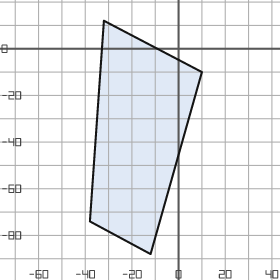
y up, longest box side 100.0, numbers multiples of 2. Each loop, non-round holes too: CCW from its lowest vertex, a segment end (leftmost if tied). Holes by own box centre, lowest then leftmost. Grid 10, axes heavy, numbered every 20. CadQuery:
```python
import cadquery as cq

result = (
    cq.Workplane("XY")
    .moveTo(-12.0, -88.0)
    .lineTo(10.0, -10.0)
    .lineTo(-32.0, 12.0)
    .lineTo(-38.0, -74.0)
    .close()
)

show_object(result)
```